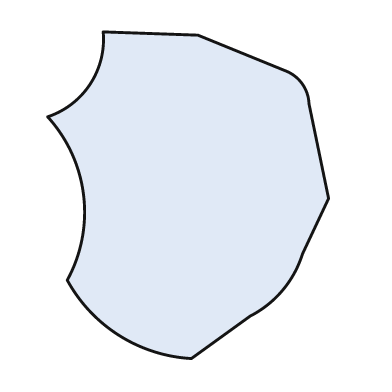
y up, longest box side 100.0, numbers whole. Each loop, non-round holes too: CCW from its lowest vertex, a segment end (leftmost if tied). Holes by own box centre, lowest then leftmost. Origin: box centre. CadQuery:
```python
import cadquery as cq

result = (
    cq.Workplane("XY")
    .moveTo(1.0, -50.0)
    .lineTo(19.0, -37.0)
    .threePointArc((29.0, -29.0), (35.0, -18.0))
    .lineTo(43.0, -1.0)
    .lineTo(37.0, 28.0)
    .threePointArc((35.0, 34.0), (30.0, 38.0))
    .lineTo(3.0, 49.0)
    .lineTo(-26.0, 50.0)
    .threePointArc((-30.0, 34.0), (-43.0, 24.0))
    .threePointArc((-32.0, 0.0), (-37.0, -26.0))
    .threePointArc((-21.0, -43.0), (1.0, -50.0))
    .close()
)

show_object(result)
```